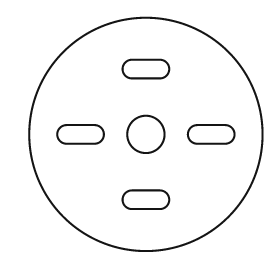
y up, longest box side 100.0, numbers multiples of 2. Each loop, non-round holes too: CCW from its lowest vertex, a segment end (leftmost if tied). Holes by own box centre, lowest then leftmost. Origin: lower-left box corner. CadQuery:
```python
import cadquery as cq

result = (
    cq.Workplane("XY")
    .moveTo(50.0, 50.0)
    .circle(50.0)
    .moveTo(44.0, 18.0)
    .lineTo(56.0, 18.0)
    .threePointArc((60.0, 22.0), (56.0, 26.0))
    .lineTo(44.0, 26.0)
    .threePointArc((40.0, 22.0), (44.0, 18.0))
    .close()
    .moveTo(16.0, 46.0)
    .lineTo(28.0, 46.0)
    .threePointArc((32.0, 50.0), (28.0, 54.0))
    .lineTo(16.0, 54.0)
    .threePointArc((12.0, 50.0), (16.0, 46.0))
    .close()
    .moveTo(50.0, 50.0)
    .circle(8.0)
    .moveTo(72.0, 46.0)
    .lineTo(84.0, 46.0)
    .threePointArc((88.0, 50.0), (84.0, 54.0))
    .lineTo(72.0, 54.0)
    .threePointArc((68.0, 50.0), (72.0, 46.0))
    .close()
    .moveTo(44.0, 74.0)
    .lineTo(56.0, 74.0)
    .threePointArc((60.0, 78.0), (56.0, 82.0))
    .lineTo(44.0, 82.0)
    .threePointArc((40.0, 78.0), (44.0, 74.0))
    .close()
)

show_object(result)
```